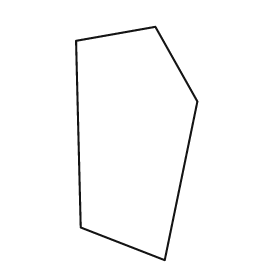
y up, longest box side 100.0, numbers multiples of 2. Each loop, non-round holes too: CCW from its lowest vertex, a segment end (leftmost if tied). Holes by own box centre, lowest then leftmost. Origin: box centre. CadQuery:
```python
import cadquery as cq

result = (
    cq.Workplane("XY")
    .moveTo(12.0, -50.0)
    .lineTo(26.0, 18.0)
    .lineTo(8.0, 50.0)
    .lineTo(-26.0, 44.0)
    .lineTo(-24.0, -36.0)
    .close()
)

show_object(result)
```